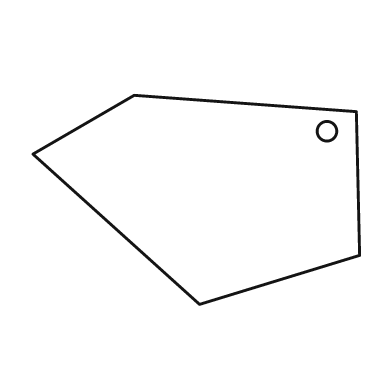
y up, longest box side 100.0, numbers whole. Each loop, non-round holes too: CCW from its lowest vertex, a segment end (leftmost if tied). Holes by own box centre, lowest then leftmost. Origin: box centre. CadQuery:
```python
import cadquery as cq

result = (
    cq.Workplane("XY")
    .moveTo(1.0, -32.0)
    .lineTo(50.0, -17.0)
    .lineTo(49.0, 27.0)
    .lineTo(-19.0, 32.0)
    .lineTo(-50.0, 14.0)
    .close()
    .moveTo(40.0, 21.0)
    .circle(3.0)
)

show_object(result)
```